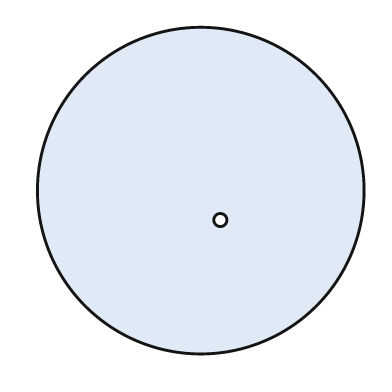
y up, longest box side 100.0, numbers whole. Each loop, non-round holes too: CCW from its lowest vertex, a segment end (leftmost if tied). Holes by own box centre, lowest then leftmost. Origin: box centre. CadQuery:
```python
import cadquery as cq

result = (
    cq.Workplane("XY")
    .moveTo(0.0, 0.0)
    .circle(50.0)
    .moveTo(6.0, -9.0)
    .circle(2.0)
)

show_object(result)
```